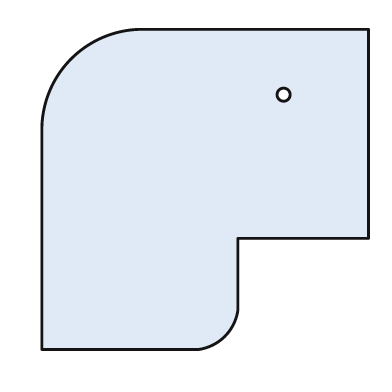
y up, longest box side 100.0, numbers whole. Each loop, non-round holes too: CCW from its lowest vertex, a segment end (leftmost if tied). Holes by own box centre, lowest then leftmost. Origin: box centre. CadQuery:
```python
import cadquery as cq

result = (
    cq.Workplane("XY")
    .moveTo(-50.0, -49.0)
    .lineTo(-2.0, -49.0)
    .threePointArc((6.0, -45.0), (10.0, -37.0))
    .lineTo(10.0, -15.0)
    .lineTo(50.0, -15.0)
    .lineTo(50.0, 49.0)
    .lineTo(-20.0, 49.0)
    .threePointArc((-41.0, 40.0), (-50.0, 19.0))
    .close()
    .moveTo(24.0, 29.0)
    .circle(2.0)
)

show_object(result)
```